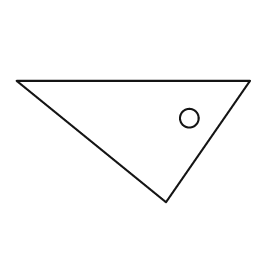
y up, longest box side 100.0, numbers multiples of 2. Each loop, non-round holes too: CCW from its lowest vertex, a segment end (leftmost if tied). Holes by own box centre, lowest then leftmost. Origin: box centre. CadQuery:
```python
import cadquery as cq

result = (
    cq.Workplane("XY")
    .moveTo(14.0, -26.0)
    .lineTo(50.0, 26.0)
    .lineTo(-50.0, 26.0)
    .close()
    .moveTo(24.0, 10.0)
    .circle(4.0)
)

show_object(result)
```